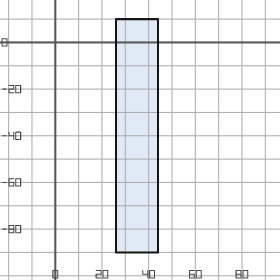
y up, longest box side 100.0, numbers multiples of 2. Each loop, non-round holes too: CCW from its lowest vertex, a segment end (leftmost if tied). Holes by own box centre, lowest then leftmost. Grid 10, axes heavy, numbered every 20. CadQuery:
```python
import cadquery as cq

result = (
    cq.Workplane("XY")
    .moveTo(26.0, -90.0)
    .lineTo(44.0, -90.0)
    .lineTo(44.0, 10.0)
    .lineTo(26.0, 10.0)
    .close()
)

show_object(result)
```